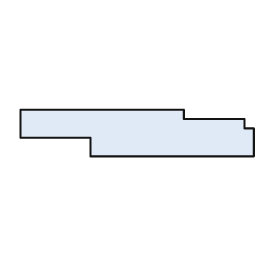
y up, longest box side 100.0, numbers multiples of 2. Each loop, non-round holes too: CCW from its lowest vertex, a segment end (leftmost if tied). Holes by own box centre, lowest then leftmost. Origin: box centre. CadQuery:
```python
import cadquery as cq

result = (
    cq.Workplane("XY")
    .moveTo(-20.0, -10.0)
    .lineTo(50.0, -10.0)
    .lineTo(50.0, 2.0)
    .lineTo(46.0, 2.0)
    .lineTo(46.0, 6.0)
    .lineTo(20.0, 6.0)
    .lineTo(20.0, 10.0)
    .lineTo(-50.0, 10.0)
    .lineTo(-50.0, -2.0)
    .lineTo(-20.0, -2.0)
    .close()
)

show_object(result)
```